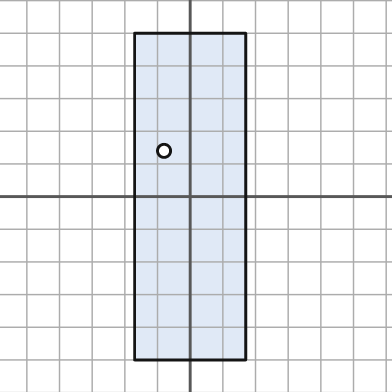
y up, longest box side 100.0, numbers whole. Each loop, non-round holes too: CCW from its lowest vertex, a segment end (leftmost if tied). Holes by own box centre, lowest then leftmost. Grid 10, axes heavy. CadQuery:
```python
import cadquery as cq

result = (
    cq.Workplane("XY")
    .moveTo(-17.0, -50.0)
    .lineTo(17.0, -50.0)
    .lineTo(17.0, 50.0)
    .lineTo(-17.0, 50.0)
    .close()
    .moveTo(-8.0, 14.0)
    .circle(2.0)
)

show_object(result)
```